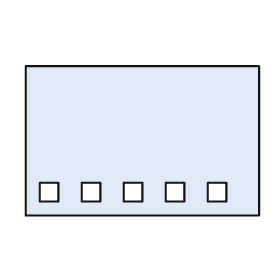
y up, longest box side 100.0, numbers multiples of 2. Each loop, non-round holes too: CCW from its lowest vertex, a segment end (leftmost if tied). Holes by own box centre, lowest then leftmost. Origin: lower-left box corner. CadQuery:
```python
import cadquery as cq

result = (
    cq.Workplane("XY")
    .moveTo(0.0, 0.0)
    .lineTo(100.0, 0.0)
    .lineTo(100.0, 64.0)
    .lineTo(0.0, 64.0)
    .close()
    .moveTo(6.0, 6.0)
    .lineTo(14.0, 6.0)
    .lineTo(14.0, 14.0)
    .lineTo(6.0, 14.0)
    .close()
    .moveTo(24.0, 6.0)
    .lineTo(32.0, 6.0)
    .lineTo(32.0, 14.0)
    .lineTo(24.0, 14.0)
    .close()
    .moveTo(42.0, 6.0)
    .lineTo(50.0, 6.0)
    .lineTo(50.0, 14.0)
    .lineTo(42.0, 14.0)
    .close()
    .moveTo(60.0, 6.0)
    .lineTo(68.0, 6.0)
    .lineTo(68.0, 14.0)
    .lineTo(60.0, 14.0)
    .close()
    .moveTo(78.0, 6.0)
    .lineTo(86.0, 6.0)
    .lineTo(86.0, 14.0)
    .lineTo(78.0, 14.0)
    .close()
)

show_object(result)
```